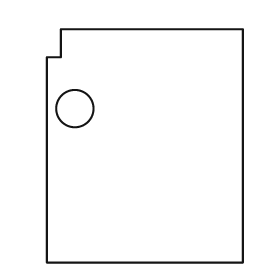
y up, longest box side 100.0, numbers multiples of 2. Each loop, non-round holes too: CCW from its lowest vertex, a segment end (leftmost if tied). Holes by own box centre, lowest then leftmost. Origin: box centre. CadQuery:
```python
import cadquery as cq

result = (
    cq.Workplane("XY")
    .moveTo(-42.0, -50.0)
    .lineTo(42.0, -50.0)
    .lineTo(42.0, 50.0)
    .lineTo(-36.0, 50.0)
    .lineTo(-36.0, 38.0)
    .lineTo(-42.0, 38.0)
    .close()
    .moveTo(-30.0, 16.0)
    .circle(8.0)
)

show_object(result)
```